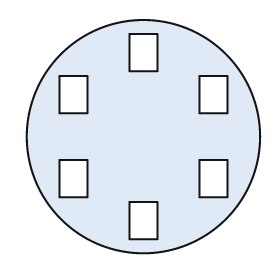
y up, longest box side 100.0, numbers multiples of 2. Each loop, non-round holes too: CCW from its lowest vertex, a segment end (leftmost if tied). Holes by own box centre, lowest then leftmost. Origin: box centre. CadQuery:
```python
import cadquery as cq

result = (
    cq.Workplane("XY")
    .moveTo(0.0, 0.0)
    .circle(50.0)
    .moveTo(-6.0, -44.0)
    .lineTo(6.0, -44.0)
    .lineTo(6.0, -28.0)
    .lineTo(-6.0, -28.0)
    .close()
    .moveTo(-36.0, -26.0)
    .lineTo(-24.0, -26.0)
    .lineTo(-24.0, -10.0)
    .lineTo(-36.0, -10.0)
    .close()
    .moveTo(24.0, -26.0)
    .lineTo(36.0, -26.0)
    .lineTo(36.0, -10.0)
    .lineTo(24.0, -10.0)
    .close()
    .moveTo(-36.0, 10.0)
    .lineTo(-24.0, 10.0)
    .lineTo(-24.0, 26.0)
    .lineTo(-36.0, 26.0)
    .close()
    .moveTo(24.0, 10.0)
    .lineTo(36.0, 10.0)
    .lineTo(36.0, 26.0)
    .lineTo(24.0, 26.0)
    .close()
    .moveTo(-6.0, 28.0)
    .lineTo(6.0, 28.0)
    .lineTo(6.0, 44.0)
    .lineTo(-6.0, 44.0)
    .close()
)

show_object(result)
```